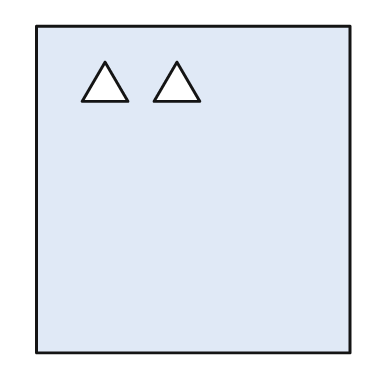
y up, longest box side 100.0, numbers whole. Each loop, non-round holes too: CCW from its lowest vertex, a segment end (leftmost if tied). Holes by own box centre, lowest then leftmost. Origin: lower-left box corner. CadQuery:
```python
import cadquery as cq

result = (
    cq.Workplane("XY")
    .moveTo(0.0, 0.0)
    .lineTo(96.0, 0.0)
    .lineTo(96.0, 100.0)
    .lineTo(0.0, 100.0)
    .close()
    .moveTo(14.0, 77.0)
    .lineTo(28.0, 77.0)
    .lineTo(21.0, 89.0)
    .close()
    .moveTo(36.0, 77.0)
    .lineTo(50.0, 77.0)
    .lineTo(43.0, 89.0)
    .close()
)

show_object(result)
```